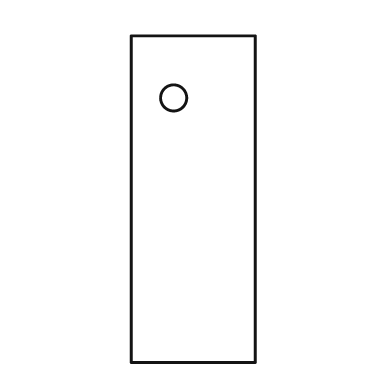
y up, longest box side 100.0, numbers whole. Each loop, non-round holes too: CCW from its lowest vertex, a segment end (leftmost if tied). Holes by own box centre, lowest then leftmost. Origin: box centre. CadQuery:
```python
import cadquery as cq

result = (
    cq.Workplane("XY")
    .moveTo(-19.0, -50.0)
    .lineTo(19.0, -50.0)
    .lineTo(19.0, 50.0)
    .lineTo(-19.0, 50.0)
    .close()
    .moveTo(-6.0, 31.0)
    .circle(4.0)
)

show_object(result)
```